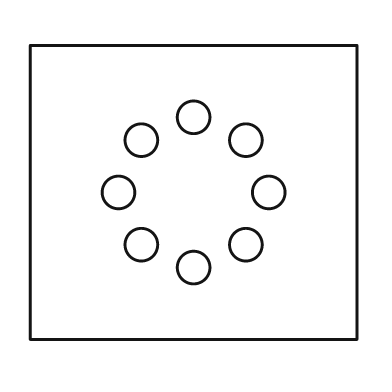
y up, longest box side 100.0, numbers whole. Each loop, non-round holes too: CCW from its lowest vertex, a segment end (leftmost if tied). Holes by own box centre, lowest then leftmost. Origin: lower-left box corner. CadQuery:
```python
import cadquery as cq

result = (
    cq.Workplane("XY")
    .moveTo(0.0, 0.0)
    .lineTo(100.0, 0.0)
    .lineTo(100.0, 90.0)
    .lineTo(0.0, 90.0)
    .close()
    .moveTo(50.0, 22.0)
    .circle(5.0)
    .moveTo(34.0, 29.0)
    .circle(5.0)
    .moveTo(66.0, 29.0)
    .circle(5.0)
    .moveTo(27.0, 45.0)
    .circle(5.0)
    .moveTo(73.0, 45.0)
    .circle(5.0)
    .moveTo(34.0, 61.0)
    .circle(5.0)
    .moveTo(66.0, 61.0)
    .circle(5.0)
    .moveTo(50.0, 68.0)
    .circle(5.0)
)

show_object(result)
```